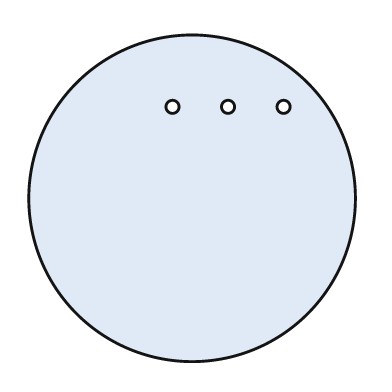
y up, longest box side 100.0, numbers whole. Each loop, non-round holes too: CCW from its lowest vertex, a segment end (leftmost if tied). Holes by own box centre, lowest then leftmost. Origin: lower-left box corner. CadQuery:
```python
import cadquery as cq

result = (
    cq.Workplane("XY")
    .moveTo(50.0, 50.0)
    .circle(50.0)
    .moveTo(44.0, 78.0)
    .circle(2.0)
    .moveTo(61.0, 78.0)
    .circle(2.0)
    .moveTo(78.0, 78.0)
    .circle(2.0)
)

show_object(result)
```